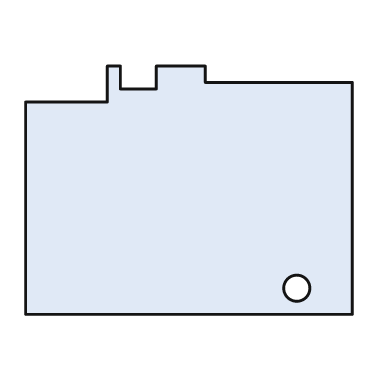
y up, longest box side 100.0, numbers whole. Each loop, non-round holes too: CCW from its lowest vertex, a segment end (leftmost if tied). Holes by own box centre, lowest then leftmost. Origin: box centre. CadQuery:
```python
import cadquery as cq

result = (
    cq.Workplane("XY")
    .moveTo(-50.0, -38.0)
    .lineTo(50.0, -38.0)
    .lineTo(50.0, 33.0)
    .lineTo(5.0, 33.0)
    .lineTo(5.0, 38.0)
    .lineTo(-10.0, 38.0)
    .lineTo(-10.0, 31.0)
    .lineTo(-21.0, 31.0)
    .lineTo(-21.0, 38.0)
    .lineTo(-25.0, 38.0)
    .lineTo(-25.0, 27.0)
    .lineTo(-50.0, 27.0)
    .close()
    .moveTo(33.0, -30.0)
    .circle(4.0)
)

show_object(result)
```